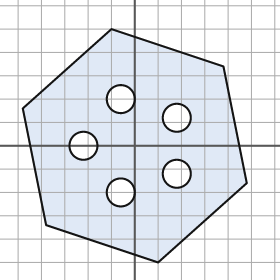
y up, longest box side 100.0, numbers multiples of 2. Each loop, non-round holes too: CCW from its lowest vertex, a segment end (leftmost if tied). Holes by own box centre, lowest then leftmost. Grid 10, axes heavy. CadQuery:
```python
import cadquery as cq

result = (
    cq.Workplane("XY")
    .moveTo(10.0, -50.0)
    .lineTo(48.0, -16.0)
    .lineTo(38.0, 34.0)
    .lineTo(-10.0, 50.0)
    .lineTo(-48.0, 16.0)
    .lineTo(-38.0, -34.0)
    .close()
    .moveTo(-6.0, -20.0)
    .circle(6.0)
    .moveTo(18.0, -12.0)
    .circle(6.0)
    .moveTo(-22.0, 0.0)
    .circle(6.0)
    .moveTo(18.0, 12.0)
    .circle(6.0)
    .moveTo(-6.0, 20.0)
    .circle(6.0)
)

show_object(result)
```